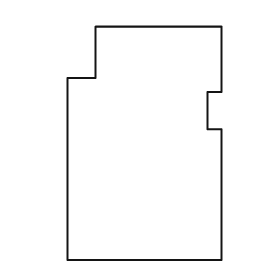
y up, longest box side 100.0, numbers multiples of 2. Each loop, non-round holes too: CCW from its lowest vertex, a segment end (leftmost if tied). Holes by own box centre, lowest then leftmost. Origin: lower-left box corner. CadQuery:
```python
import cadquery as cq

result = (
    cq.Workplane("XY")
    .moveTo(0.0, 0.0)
    .lineTo(66.0, 0.0)
    .lineTo(66.0, 56.0)
    .lineTo(60.0, 56.0)
    .lineTo(60.0, 72.0)
    .lineTo(66.0, 72.0)
    .lineTo(66.0, 100.0)
    .lineTo(12.0, 100.0)
    .lineTo(12.0, 78.0)
    .lineTo(0.0, 78.0)
    .close()
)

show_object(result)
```